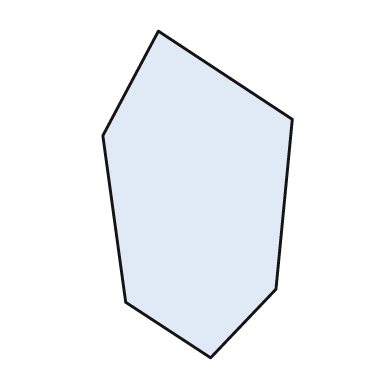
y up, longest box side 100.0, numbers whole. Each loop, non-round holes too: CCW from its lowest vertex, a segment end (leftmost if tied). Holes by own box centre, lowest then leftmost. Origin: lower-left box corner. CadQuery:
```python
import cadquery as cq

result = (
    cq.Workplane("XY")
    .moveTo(33.0, 0.0)
    .lineTo(53.0, 21.0)
    .lineTo(58.0, 73.0)
    .lineTo(17.0, 100.0)
    .lineTo(0.0, 68.0)
    .lineTo(7.0, 17.0)
    .close()
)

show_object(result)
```